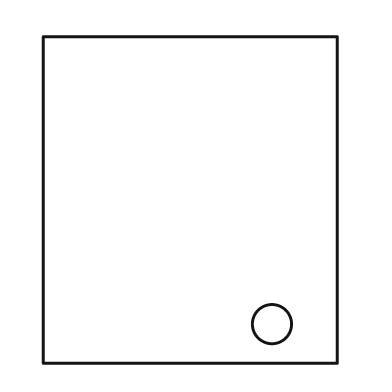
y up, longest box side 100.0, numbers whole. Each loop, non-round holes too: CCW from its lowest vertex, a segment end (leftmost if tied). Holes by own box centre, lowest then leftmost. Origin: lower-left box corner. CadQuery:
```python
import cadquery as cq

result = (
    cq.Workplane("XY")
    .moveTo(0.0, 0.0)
    .lineTo(90.0, 0.0)
    .lineTo(90.0, 100.0)
    .lineTo(0.0, 100.0)
    .close()
    .moveTo(70.0, 12.0)
    .circle(6.0)
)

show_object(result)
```